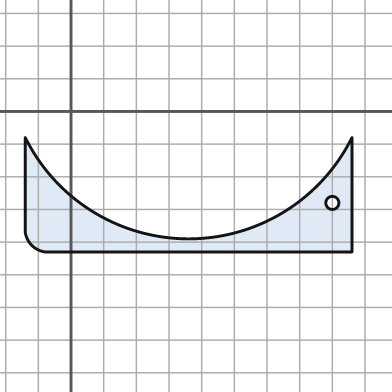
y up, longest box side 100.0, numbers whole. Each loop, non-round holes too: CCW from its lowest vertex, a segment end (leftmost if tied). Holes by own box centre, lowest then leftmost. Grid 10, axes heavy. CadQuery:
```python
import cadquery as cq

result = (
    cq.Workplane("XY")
    .moveTo(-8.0, -43.0)
    .lineTo(86.0, -43.0)
    .lineTo(86.0, -8.0)
    .threePointArc((36.0, -39.0), (-14.0, -8.0))
    .lineTo(-14.0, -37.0)
    .threePointArc((-12.0, -41.0), (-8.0, -43.0))
    .close()
    .moveTo(80.0, -28.0)
    .circle(2.0)
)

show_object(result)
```